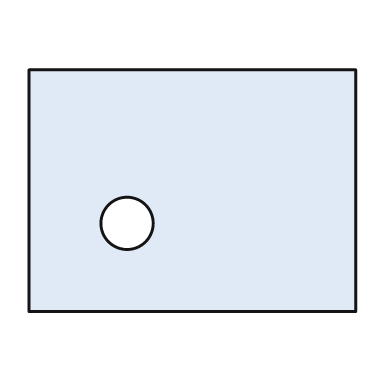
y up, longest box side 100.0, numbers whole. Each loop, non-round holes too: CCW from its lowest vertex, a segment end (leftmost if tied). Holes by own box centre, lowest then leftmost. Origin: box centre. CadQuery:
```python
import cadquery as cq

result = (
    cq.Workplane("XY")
    .moveTo(-50.0, -37.0)
    .lineTo(50.0, -37.0)
    .lineTo(50.0, 37.0)
    .lineTo(-50.0, 37.0)
    .close()
    .moveTo(-20.0, -10.0)
    .circle(8.0)
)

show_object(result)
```